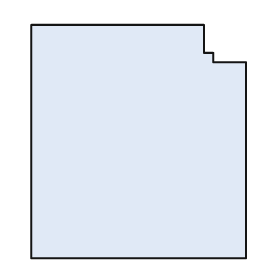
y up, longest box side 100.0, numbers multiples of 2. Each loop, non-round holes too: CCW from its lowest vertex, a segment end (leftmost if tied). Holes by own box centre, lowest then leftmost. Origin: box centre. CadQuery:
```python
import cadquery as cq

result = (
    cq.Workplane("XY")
    .moveTo(-46.0, -50.0)
    .lineTo(46.0, -50.0)
    .lineTo(46.0, 34.0)
    .lineTo(32.0, 34.0)
    .lineTo(32.0, 38.0)
    .lineTo(28.0, 38.0)
    .lineTo(28.0, 50.0)
    .lineTo(-46.0, 50.0)
    .close()
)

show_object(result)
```